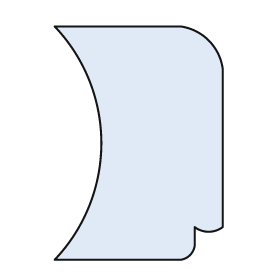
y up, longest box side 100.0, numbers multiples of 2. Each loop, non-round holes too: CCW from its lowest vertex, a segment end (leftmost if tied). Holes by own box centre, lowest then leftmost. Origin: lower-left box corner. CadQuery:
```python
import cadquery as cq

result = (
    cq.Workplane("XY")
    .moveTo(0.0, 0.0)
    .lineTo(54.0, 0.0)
    .threePointArc((58.0, 2.0), (60.0, 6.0))
    .lineTo(60.0, 14.0)
    .threePointArc((66.0, 12.0), (72.0, 14.0))
    .lineTo(72.0, 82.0)
    .threePointArc((66.0, 94.0), (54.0, 100.0))
    .lineTo(0.0, 100.0)
    .threePointArc((20.0, 50.0), (0.0, 0.0))
    .close()
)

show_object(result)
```